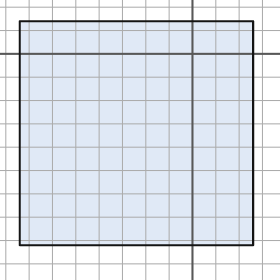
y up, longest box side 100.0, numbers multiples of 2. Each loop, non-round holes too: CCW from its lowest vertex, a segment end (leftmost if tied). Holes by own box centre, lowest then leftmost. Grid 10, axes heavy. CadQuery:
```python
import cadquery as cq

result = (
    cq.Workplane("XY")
    .moveTo(-74.0, -82.0)
    .lineTo(26.0, -82.0)
    .lineTo(26.0, 14.0)
    .lineTo(-74.0, 14.0)
    .close()
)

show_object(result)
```